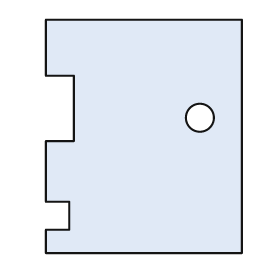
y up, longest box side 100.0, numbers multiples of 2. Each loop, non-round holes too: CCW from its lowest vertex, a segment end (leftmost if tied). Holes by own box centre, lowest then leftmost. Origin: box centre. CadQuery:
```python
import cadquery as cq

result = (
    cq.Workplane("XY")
    .moveTo(-42.0, -50.0)
    .lineTo(42.0, -50.0)
    .lineTo(42.0, 50.0)
    .lineTo(-42.0, 50.0)
    .lineTo(-42.0, 26.0)
    .lineTo(-30.0, 26.0)
    .lineTo(-30.0, -2.0)
    .lineTo(-42.0, -2.0)
    .lineTo(-42.0, -28.0)
    .lineTo(-32.0, -28.0)
    .lineTo(-32.0, -40.0)
    .lineTo(-42.0, -40.0)
    .close()
    .moveTo(24.0, 8.0)
    .circle(6.0)
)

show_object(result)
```